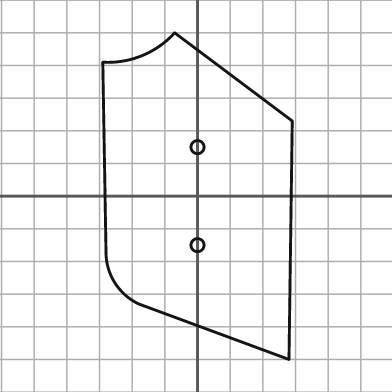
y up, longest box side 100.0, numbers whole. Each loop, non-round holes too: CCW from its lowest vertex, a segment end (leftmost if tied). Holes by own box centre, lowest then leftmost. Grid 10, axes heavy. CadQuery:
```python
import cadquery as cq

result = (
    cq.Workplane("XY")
    .moveTo(28.0, -50.0)
    .lineTo(29.0, 23.0)
    .lineTo(-7.0, 50.0)
    .threePointArc((-17.0, 43.0), (-29.0, 41.0))
    .lineTo(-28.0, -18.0)
    .threePointArc((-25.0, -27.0), (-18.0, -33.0))
    .close()
    .moveTo(0.0, -15.0)
    .circle(2.0)
    .moveTo(0.0, 15.0)
    .circle(2.0)
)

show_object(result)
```